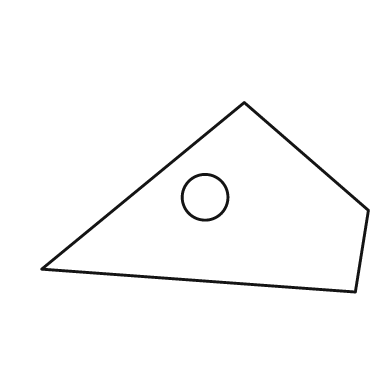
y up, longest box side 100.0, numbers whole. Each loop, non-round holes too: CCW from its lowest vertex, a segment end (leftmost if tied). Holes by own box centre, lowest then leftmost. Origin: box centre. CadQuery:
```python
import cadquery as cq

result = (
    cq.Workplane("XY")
    .moveTo(46.0, -29.0)
    .lineTo(50.0, -4.0)
    .lineTo(12.0, 29.0)
    .lineTo(-50.0, -22.0)
    .close()
    .moveTo(0.0, 0.0)
    .circle(7.0)
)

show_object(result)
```